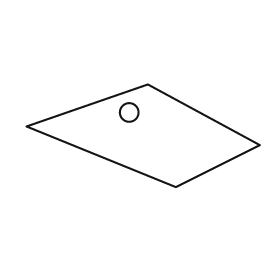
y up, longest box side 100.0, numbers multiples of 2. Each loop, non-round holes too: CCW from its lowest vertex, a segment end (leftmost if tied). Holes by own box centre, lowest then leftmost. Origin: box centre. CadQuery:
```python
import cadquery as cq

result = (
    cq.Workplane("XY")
    .moveTo(14.0, -22.0)
    .lineTo(50.0, -4.0)
    .lineTo(2.0, 22.0)
    .lineTo(-50.0, 4.0)
    .close()
    .moveTo(-6.0, 10.0)
    .circle(4.0)
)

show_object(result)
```